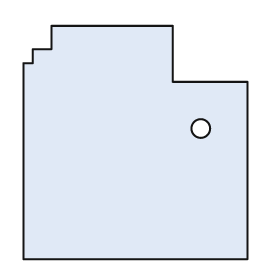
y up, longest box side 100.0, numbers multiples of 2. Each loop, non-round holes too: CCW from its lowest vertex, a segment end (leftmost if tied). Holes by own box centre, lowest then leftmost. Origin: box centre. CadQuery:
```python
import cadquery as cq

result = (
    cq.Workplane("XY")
    .moveTo(-48.0, -50.0)
    .lineTo(48.0, -50.0)
    .lineTo(48.0, 26.0)
    .lineTo(16.0, 26.0)
    .lineTo(16.0, 50.0)
    .lineTo(-36.0, 50.0)
    .lineTo(-36.0, 40.0)
    .lineTo(-44.0, 40.0)
    .lineTo(-44.0, 34.0)
    .lineTo(-48.0, 34.0)
    .close()
    .moveTo(28.0, 6.0)
    .circle(4.0)
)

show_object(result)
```